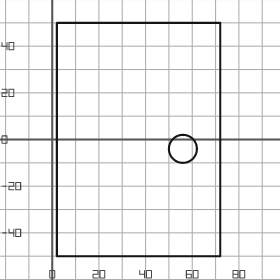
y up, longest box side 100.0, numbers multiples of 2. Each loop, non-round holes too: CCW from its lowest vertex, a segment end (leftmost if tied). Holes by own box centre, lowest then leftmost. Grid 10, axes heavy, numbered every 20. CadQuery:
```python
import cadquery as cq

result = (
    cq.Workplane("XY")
    .moveTo(2.0, -50.0)
    .lineTo(72.0, -50.0)
    .lineTo(72.0, 50.0)
    .lineTo(2.0, 50.0)
    .close()
    .moveTo(56.0, -4.0)
    .circle(6.0)
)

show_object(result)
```